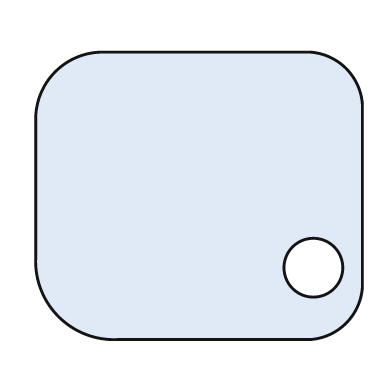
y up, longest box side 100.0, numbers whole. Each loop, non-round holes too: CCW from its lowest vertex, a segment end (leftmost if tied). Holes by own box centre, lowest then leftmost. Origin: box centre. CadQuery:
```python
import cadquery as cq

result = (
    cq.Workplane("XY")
    .moveTo(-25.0, -44.0)
    .lineTo(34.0, -44.0)
    .threePointArc((45.0, -39.0), (50.0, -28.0))
    .lineTo(50.0, 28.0)
    .threePointArc((45.0, 39.0), (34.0, 44.0))
    .lineTo(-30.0, 44.0)
    .threePointArc((-44.0, 38.0), (-50.0, 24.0))
    .lineTo(-50.0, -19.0)
    .threePointArc((-43.0, -37.0), (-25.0, -44.0))
    .close()
    .moveTo(35.0, -22.0)
    .circle(9.0)
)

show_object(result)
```